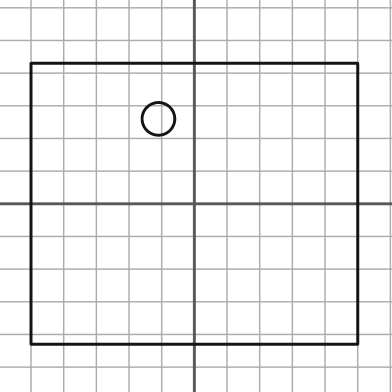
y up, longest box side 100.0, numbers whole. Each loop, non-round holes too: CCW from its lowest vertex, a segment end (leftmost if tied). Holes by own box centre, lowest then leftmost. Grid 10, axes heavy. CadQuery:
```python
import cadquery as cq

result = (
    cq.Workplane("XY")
    .moveTo(-50.0, -43.0)
    .lineTo(50.0, -43.0)
    .lineTo(50.0, 43.0)
    .lineTo(-50.0, 43.0)
    .close()
    .moveTo(-11.0, 26.0)
    .circle(5.0)
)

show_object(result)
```